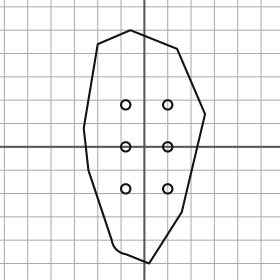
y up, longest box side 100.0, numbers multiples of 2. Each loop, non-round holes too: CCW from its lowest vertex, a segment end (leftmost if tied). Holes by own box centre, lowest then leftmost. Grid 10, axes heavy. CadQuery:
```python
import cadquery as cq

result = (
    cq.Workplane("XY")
    .moveTo(2.0, -50.0)
    .lineTo(16.0, -28.0)
    .lineTo(26.0, 14.0)
    .lineTo(14.0, 42.0)
    .lineTo(-6.0, 50.0)
    .lineTo(-20.0, 44.0)
    .lineTo(-26.0, 8.0)
    .lineTo(-24.0, -10.0)
    .lineTo(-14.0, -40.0)
    .threePointArc((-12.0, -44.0), (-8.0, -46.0))
    .close()
    .moveTo(-8.0, -18.0)
    .circle(2.0)
    .moveTo(10.0, -18.0)
    .circle(2.0)
    .moveTo(-8.0, 0.0)
    .circle(2.0)
    .moveTo(10.0, 0.0)
    .circle(2.0)
    .moveTo(-8.0, 18.0)
    .circle(2.0)
    .moveTo(10.0, 18.0)
    .circle(2.0)
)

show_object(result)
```